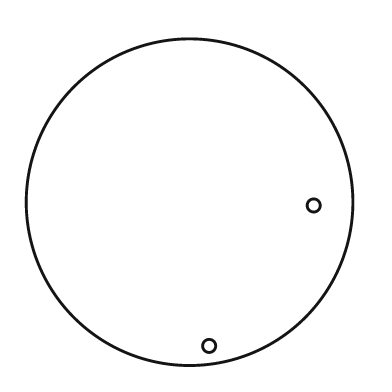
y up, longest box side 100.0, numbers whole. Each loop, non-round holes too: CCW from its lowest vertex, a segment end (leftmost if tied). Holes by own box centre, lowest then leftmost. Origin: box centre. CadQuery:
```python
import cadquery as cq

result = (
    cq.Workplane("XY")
    .moveTo(0.0, 0.0)
    .circle(50.0)
    .moveTo(6.0, -44.0)
    .circle(2.0)
    .moveTo(38.0, -1.0)
    .circle(2.0)
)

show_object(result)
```